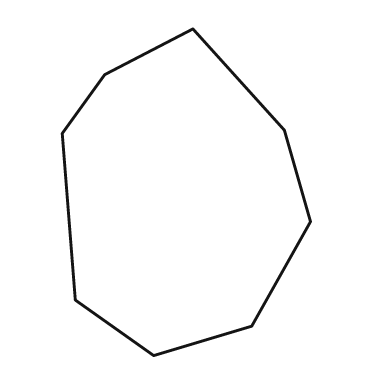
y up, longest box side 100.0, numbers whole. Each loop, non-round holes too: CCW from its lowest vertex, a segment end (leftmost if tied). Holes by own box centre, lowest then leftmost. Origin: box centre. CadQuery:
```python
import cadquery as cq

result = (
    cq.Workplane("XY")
    .moveTo(-10.0, -50.0)
    .lineTo(20.0, -41.0)
    .lineTo(38.0, -9.0)
    .lineTo(30.0, 19.0)
    .lineTo(2.0, 50.0)
    .lineTo(-25.0, 36.0)
    .lineTo(-38.0, 18.0)
    .lineTo(-34.0, -33.0)
    .close()
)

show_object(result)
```